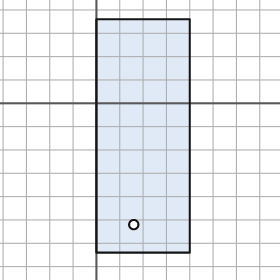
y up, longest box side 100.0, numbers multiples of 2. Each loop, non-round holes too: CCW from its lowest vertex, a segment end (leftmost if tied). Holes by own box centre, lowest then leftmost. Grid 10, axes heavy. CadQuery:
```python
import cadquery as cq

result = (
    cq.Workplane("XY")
    .moveTo(0.0, -64.0)
    .lineTo(40.0, -64.0)
    .lineTo(40.0, 36.0)
    .lineTo(0.0, 36.0)
    .close()
    .moveTo(16.0, -52.0)
    .circle(2.0)
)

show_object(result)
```